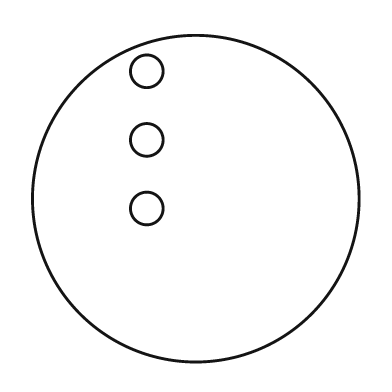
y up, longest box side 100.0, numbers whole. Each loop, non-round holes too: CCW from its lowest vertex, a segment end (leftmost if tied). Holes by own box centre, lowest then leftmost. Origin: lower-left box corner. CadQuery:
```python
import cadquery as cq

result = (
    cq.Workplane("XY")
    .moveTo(50.0, 50.0)
    .circle(50.0)
    .moveTo(35.0, 47.0)
    .circle(5.0)
    .moveTo(35.0, 68.0)
    .circle(5.0)
    .moveTo(35.0, 89.0)
    .circle(5.0)
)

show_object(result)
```